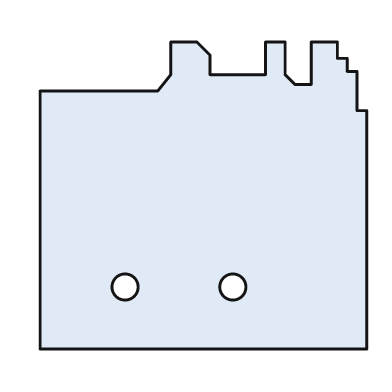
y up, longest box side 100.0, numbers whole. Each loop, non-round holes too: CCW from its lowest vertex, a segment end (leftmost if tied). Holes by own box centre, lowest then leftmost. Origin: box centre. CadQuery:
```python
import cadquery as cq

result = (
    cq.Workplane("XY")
    .moveTo(-50.0, -47.0)
    .lineTo(50.0, -47.0)
    .lineTo(50.0, 26.0)
    .lineTo(47.0, 26.0)
    .lineTo(47.0, 38.0)
    .lineTo(44.0, 38.0)
    .lineTo(44.0, 42.0)
    .lineTo(41.0, 42.0)
    .lineTo(41.0, 47.0)
    .lineTo(33.0, 47.0)
    .lineTo(33.0, 34.0)
    .lineTo(28.0, 34.0)
    .lineTo(25.0, 37.0)
    .lineTo(25.0, 47.0)
    .lineTo(19.0, 47.0)
    .lineTo(19.0, 37.0)
    .lineTo(2.0, 37.0)
    .lineTo(2.0, 43.0)
    .lineTo(-2.0, 47.0)
    .lineTo(-10.0, 47.0)
    .lineTo(-10.0, 37.0)
    .lineTo(-14.0, 32.0)
    .lineTo(-50.0, 32.0)
    .close()
    .moveTo(-24.0, -28.0)
    .circle(4.0)
    .moveTo(9.0, -28.0)
    .circle(4.0)
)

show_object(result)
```